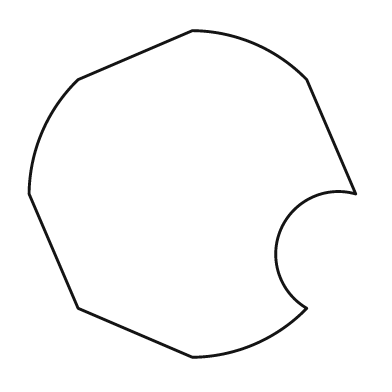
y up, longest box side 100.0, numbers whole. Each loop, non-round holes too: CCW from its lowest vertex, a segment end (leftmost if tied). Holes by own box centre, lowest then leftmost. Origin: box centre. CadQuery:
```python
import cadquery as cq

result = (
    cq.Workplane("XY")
    .moveTo(0.0, -50.0)
    .threePointArc((19.0, -46.0), (35.0, -35.0))
    .threePointArc((27.0, -11.0), (50.0, 0.0))
    .lineTo(35.0, 35.0)
    .threePointArc((19.0, 46.0), (0.0, 50.0))
    .lineTo(-35.0, 35.0)
    .threePointArc((-46.0, 19.0), (-50.0, 0.0))
    .lineTo(-35.0, -35.0)
    .close()
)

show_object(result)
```